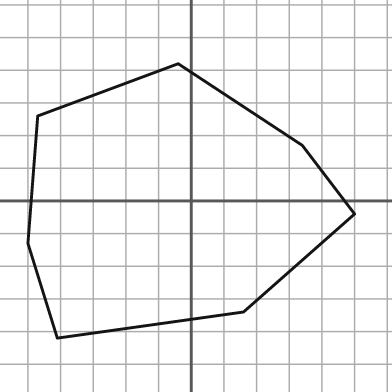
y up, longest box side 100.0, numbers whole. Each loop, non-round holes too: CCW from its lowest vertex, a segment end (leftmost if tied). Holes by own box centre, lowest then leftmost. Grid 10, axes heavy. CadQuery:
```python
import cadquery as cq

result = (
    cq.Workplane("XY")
    .moveTo(-41.0, -42.0)
    .lineTo(16.0, -34.0)
    .lineTo(50.0, -4.0)
    .lineTo(34.0, 17.0)
    .lineTo(-4.0, 42.0)
    .lineTo(-47.0, 26.0)
    .lineTo(-50.0, -13.0)
    .close()
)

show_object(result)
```